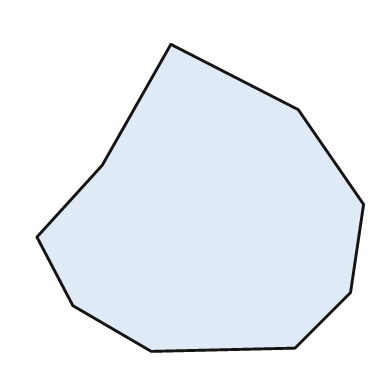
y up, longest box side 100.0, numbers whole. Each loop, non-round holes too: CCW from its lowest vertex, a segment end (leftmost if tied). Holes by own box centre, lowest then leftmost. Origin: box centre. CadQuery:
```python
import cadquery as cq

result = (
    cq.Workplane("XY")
    .moveTo(-15.0, -47.0)
    .lineTo(29.0, -46.0)
    .lineTo(46.0, -29.0)
    .lineTo(50.0, -2.0)
    .lineTo(30.0, 27.0)
    .lineTo(-9.0, 47.0)
    .lineTo(-30.0, 10.0)
    .lineTo(-50.0, -12.0)
    .lineTo(-39.0, -33.0)
    .close()
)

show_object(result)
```